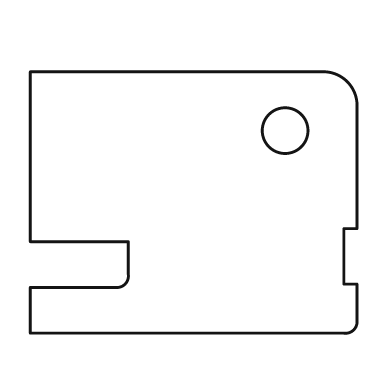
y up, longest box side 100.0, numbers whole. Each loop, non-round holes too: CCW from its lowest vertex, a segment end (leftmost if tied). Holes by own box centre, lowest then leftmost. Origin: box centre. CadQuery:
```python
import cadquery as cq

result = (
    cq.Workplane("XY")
    .moveTo(-50.0, -40.0)
    .lineTo(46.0, -40.0)
    .threePointArc((49.0, -39.0), (50.0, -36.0))
    .lineTo(50.0, -25.0)
    .lineTo(46.0, -25.0)
    .lineTo(46.0, -8.0)
    .lineTo(50.0, -8.0)
    .lineTo(50.0, 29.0)
    .threePointArc((47.0, 37.0), (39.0, 40.0))
    .lineTo(-50.0, 40.0)
    .lineTo(-50.0, -12.0)
    .lineTo(-20.0, -12.0)
    .lineTo(-20.0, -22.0)
    .threePointArc((-21.0, -25.0), (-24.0, -26.0))
    .lineTo(-50.0, -26.0)
    .close()
    .moveTo(28.0, 22.0)
    .circle(7.0)
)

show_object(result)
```